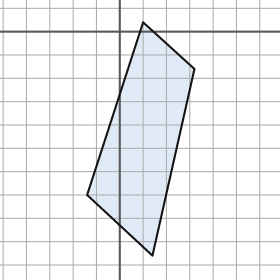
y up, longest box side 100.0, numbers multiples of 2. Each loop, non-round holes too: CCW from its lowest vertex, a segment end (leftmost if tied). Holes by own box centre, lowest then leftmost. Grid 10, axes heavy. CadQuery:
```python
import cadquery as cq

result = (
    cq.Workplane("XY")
    .moveTo(14.0, -96.0)
    .lineTo(32.0, -16.0)
    .lineTo(10.0, 4.0)
    .lineTo(-14.0, -70.0)
    .close()
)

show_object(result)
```